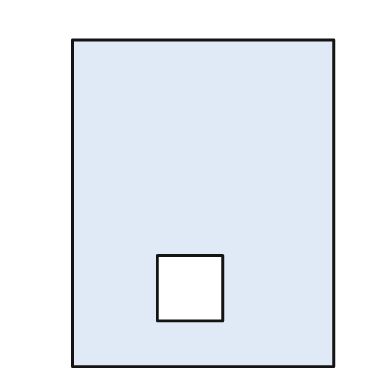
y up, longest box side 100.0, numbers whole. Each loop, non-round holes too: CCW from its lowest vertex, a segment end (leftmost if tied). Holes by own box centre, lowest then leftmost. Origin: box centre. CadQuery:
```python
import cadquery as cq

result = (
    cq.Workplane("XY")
    .moveTo(-40.0, -50.0)
    .lineTo(40.0, -50.0)
    .lineTo(40.0, 50.0)
    .lineTo(-40.0, 50.0)
    .close()
    .moveTo(-14.0, -36.0)
    .lineTo(6.0, -36.0)
    .lineTo(6.0, -16.0)
    .lineTo(-14.0, -16.0)
    .close()
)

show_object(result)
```